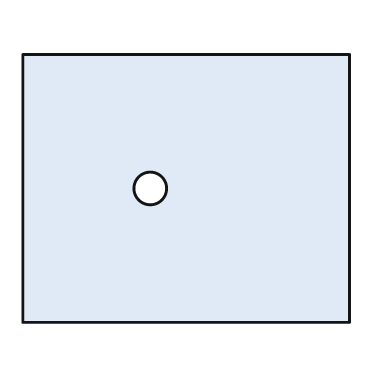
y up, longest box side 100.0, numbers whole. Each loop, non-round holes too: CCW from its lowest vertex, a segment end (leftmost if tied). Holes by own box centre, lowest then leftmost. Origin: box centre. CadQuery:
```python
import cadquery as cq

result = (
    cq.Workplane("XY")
    .moveTo(-50.0, -41.0)
    .lineTo(50.0, -41.0)
    .lineTo(50.0, 41.0)
    .lineTo(-50.0, 41.0)
    .close()
    .moveTo(-11.0, 0.0)
    .circle(5.0)
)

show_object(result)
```